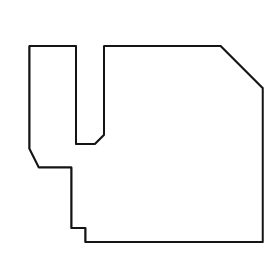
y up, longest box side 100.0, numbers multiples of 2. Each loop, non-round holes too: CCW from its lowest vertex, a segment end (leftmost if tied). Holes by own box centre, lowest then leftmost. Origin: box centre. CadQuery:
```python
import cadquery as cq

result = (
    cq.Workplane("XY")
    .moveTo(-26.0, -42.0)
    .lineTo(50.0, -42.0)
    .lineTo(50.0, 24.0)
    .lineTo(32.0, 42.0)
    .lineTo(-18.0, 42.0)
    .lineTo(-18.0, 4.0)
    .lineTo(-22.0, 0.0)
    .lineTo(-30.0, 0.0)
    .lineTo(-30.0, 42.0)
    .lineTo(-50.0, 42.0)
    .lineTo(-50.0, -2.0)
    .lineTo(-46.0, -10.0)
    .lineTo(-32.0, -10.0)
    .lineTo(-32.0, -36.0)
    .lineTo(-26.0, -36.0)
    .close()
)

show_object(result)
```